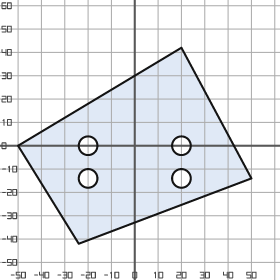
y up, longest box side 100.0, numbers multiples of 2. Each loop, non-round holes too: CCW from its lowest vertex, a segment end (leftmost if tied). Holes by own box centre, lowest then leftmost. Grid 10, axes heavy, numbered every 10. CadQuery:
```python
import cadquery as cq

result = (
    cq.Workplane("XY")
    .moveTo(-24.0, -42.0)
    .lineTo(50.0, -14.0)
    .lineTo(20.0, 42.0)
    .lineTo(-50.0, 0.0)
    .close()
    .moveTo(-20.0, -14.0)
    .circle(4.0)
    .moveTo(20.0, -14.0)
    .circle(4.0)
    .moveTo(-20.0, 0.0)
    .circle(4.0)
    .moveTo(20.0, 0.0)
    .circle(4.0)
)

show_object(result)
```